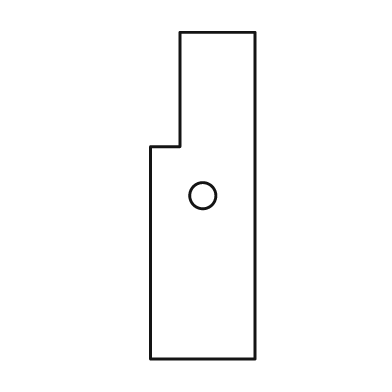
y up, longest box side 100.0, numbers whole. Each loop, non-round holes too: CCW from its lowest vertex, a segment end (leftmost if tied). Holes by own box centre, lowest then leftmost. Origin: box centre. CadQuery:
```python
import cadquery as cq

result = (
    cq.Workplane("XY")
    .moveTo(-16.0, -50.0)
    .lineTo(16.0, -50.0)
    .lineTo(16.0, 50.0)
    .lineTo(-7.0, 50.0)
    .lineTo(-7.0, 15.0)
    .lineTo(-16.0, 15.0)
    .close()
    .moveTo(0.0, 0.0)
    .circle(4.0)
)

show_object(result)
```